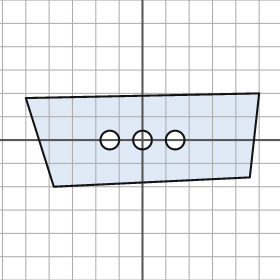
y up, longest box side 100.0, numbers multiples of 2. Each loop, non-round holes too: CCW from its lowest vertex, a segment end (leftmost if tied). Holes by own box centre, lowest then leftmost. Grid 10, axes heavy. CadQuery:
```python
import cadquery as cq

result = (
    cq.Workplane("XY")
    .moveTo(-38.0, -20.0)
    .lineTo(46.0, -16.0)
    .lineTo(50.0, 20.0)
    .lineTo(-50.0, 18.0)
    .close()
    .moveTo(-14.0, 0.0)
    .circle(4.0)
    .moveTo(0.0, 0.0)
    .circle(4.0)
    .moveTo(14.0, 0.0)
    .circle(4.0)
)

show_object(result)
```